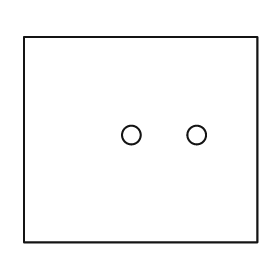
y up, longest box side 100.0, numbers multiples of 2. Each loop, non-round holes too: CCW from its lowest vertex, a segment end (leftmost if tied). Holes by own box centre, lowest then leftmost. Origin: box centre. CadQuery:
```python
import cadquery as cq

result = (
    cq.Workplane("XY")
    .moveTo(-50.0, -44.0)
    .lineTo(50.0, -44.0)
    .lineTo(50.0, 44.0)
    .lineTo(-50.0, 44.0)
    .close()
    .moveTo(-4.0, 2.0)
    .circle(4.0)
    .moveTo(24.0, 2.0)
    .circle(4.0)
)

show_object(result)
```